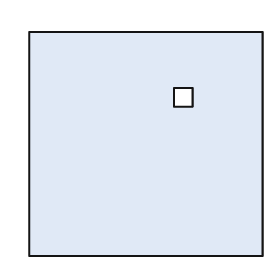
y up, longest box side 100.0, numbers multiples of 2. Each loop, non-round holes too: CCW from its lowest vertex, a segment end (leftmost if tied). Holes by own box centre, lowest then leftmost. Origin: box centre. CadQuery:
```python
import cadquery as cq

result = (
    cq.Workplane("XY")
    .moveTo(-50.0, -48.0)
    .lineTo(50.0, -48.0)
    .lineTo(50.0, 48.0)
    .lineTo(-50.0, 48.0)
    .close()
    .moveTo(12.0, 16.0)
    .lineTo(20.0, 16.0)
    .lineTo(20.0, 24.0)
    .lineTo(12.0, 24.0)
    .close()
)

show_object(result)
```